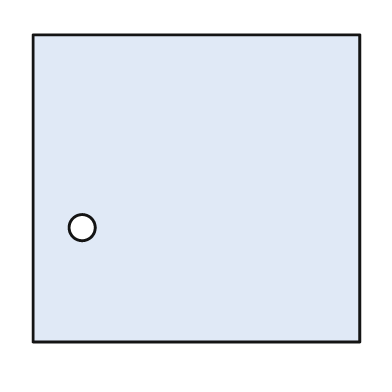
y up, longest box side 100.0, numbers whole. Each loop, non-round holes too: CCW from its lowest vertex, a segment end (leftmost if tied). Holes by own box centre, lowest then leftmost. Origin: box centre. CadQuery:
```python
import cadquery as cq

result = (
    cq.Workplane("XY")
    .moveTo(-50.0, -47.0)
    .lineTo(50.0, -47.0)
    .lineTo(50.0, 47.0)
    .lineTo(-50.0, 47.0)
    .close()
    .moveTo(-35.0, -12.0)
    .circle(4.0)
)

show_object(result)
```